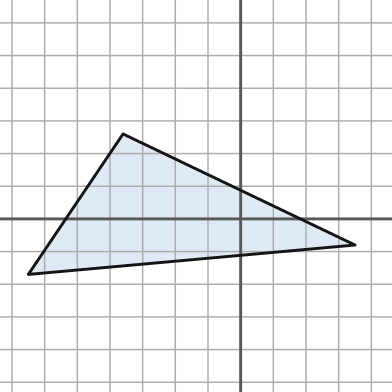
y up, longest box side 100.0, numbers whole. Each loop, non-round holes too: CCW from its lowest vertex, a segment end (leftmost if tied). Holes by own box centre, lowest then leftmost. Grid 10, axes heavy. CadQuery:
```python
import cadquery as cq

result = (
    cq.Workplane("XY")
    .moveTo(-65.0, -17.0)
    .lineTo(35.0, -8.0)
    .lineTo(-36.0, 26.0)
    .close()
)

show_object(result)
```